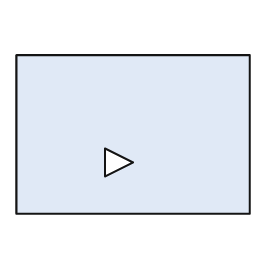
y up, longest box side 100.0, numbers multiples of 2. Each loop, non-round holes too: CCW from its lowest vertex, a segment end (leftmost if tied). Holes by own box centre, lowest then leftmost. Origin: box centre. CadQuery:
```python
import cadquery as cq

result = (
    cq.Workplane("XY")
    .moveTo(-50.0, -34.0)
    .lineTo(50.0, -34.0)
    .lineTo(50.0, 34.0)
    .lineTo(-50.0, 34.0)
    .close()
    .moveTo(-12.0, -18.0)
    .lineTo(0.0, -12.0)
    .lineTo(-12.0, -6.0)
    .close()
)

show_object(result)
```